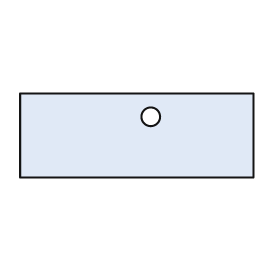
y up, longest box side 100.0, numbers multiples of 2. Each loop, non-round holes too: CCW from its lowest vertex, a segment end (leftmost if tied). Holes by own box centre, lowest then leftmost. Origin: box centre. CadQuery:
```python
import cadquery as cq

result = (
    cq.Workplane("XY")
    .moveTo(-50.0, -18.0)
    .lineTo(50.0, -18.0)
    .lineTo(50.0, 18.0)
    .lineTo(-50.0, 18.0)
    .close()
    .moveTo(6.0, 8.0)
    .circle(4.0)
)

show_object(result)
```